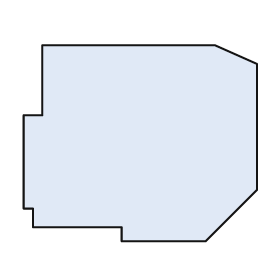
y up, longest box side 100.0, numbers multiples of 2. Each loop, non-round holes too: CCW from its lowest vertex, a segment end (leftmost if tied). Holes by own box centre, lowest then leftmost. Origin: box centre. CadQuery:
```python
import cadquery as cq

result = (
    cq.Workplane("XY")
    .moveTo(-8.0, -42.0)
    .lineTo(28.0, -42.0)
    .lineTo(50.0, -20.0)
    .lineTo(50.0, 34.0)
    .lineTo(32.0, 42.0)
    .lineTo(-42.0, 42.0)
    .lineTo(-42.0, 12.0)
    .lineTo(-50.0, 12.0)
    .lineTo(-50.0, -28.0)
    .lineTo(-46.0, -28.0)
    .lineTo(-46.0, -36.0)
    .lineTo(-8.0, -36.0)
    .close()
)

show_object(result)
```